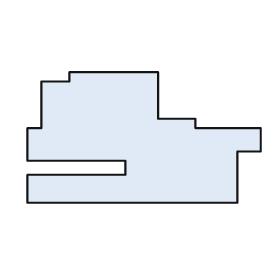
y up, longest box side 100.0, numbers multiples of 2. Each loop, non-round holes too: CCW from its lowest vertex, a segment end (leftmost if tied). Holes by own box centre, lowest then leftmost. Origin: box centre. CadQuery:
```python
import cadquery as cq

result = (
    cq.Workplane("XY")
    .moveTo(-50.0, -28.0)
    .lineTo(40.0, -28.0)
    .lineTo(40.0, -6.0)
    .lineTo(50.0, -6.0)
    .lineTo(50.0, 4.0)
    .lineTo(22.0, 4.0)
    .lineTo(22.0, 8.0)
    .lineTo(6.0, 8.0)
    .lineTo(6.0, 28.0)
    .lineTo(-32.0, 28.0)
    .lineTo(-32.0, 24.0)
    .lineTo(-44.0, 24.0)
    .lineTo(-44.0, 4.0)
    .lineTo(-50.0, 4.0)
    .lineTo(-50.0, -10.0)
    .lineTo(-8.0, -10.0)
    .lineTo(-8.0, -16.0)
    .lineTo(-50.0, -16.0)
    .close()
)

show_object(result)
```